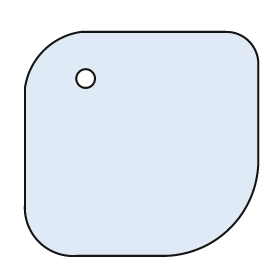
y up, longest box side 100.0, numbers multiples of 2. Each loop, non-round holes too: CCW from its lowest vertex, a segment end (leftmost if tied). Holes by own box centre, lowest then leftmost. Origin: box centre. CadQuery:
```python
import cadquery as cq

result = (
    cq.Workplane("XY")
    .moveTo(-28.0, -48.0)
    .lineTo(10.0, -48.0)
    .threePointArc((38.0, -36.0), (50.0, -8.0))
    .lineTo(50.0, 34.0)
    .threePointArc((46.0, 44.0), (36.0, 48.0))
    .lineTo(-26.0, 48.0)
    .threePointArc((-42.0, 40.0), (-50.0, 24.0))
    .lineTo(-50.0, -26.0)
    .threePointArc((-44.0, -42.0), (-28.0, -48.0))
    .close()
    .moveTo(-24.0, 28.0)
    .circle(4.0)
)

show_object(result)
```